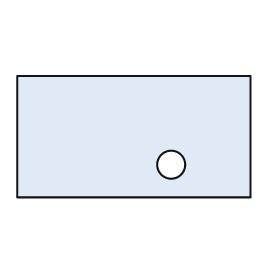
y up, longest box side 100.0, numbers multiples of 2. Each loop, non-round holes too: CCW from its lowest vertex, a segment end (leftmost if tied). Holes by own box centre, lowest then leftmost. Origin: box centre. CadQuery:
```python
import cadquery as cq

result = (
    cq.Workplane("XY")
    .moveTo(-50.0, -26.0)
    .lineTo(50.0, -26.0)
    .lineTo(50.0, 26.0)
    .lineTo(-50.0, 26.0)
    .close()
    .moveTo(16.0, -12.0)
    .circle(6.0)
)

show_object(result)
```